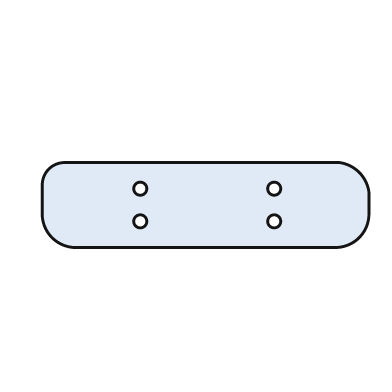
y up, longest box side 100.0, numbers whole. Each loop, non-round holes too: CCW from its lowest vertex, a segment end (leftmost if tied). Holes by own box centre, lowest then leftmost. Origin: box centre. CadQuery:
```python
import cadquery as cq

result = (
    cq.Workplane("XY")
    .moveTo(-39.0, -13.0)
    .lineTo(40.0, -13.0)
    .threePointArc((47.0, -10.0), (50.0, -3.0))
    .lineTo(50.0, 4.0)
    .threePointArc((47.0, 10.0), (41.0, 13.0))
    .lineTo(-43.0, 13.0)
    .threePointArc((-48.0, 11.0), (-50.0, 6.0))
    .lineTo(-50.0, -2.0)
    .threePointArc((-47.0, -10.0), (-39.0, -13.0))
    .close()
    .moveTo(-20.0, -5.0)
    .circle(2.0)
    .moveTo(21.0, -5.0)
    .circle(2.0)
    .moveTo(-20.0, 5.0)
    .circle(2.0)
    .moveTo(21.0, 5.0)
    .circle(2.0)
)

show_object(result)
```